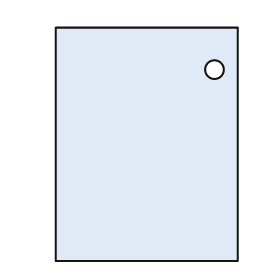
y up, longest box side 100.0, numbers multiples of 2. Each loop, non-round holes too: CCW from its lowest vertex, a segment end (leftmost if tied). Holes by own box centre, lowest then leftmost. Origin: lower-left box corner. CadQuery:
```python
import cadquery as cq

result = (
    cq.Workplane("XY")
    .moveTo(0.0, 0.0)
    .lineTo(78.0, 0.0)
    .lineTo(78.0, 100.0)
    .lineTo(0.0, 100.0)
    .close()
    .moveTo(68.0, 82.0)
    .circle(4.0)
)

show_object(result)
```